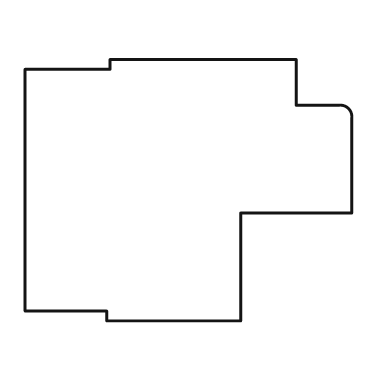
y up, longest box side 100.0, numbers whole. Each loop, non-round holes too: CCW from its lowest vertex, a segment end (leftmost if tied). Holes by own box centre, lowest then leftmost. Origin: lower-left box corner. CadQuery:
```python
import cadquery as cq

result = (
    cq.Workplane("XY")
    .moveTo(25.0, 0.0)
    .lineTo(66.0, 0.0)
    .lineTo(66.0, 33.0)
    .lineTo(100.0, 33.0)
    .lineTo(100.0, 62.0)
    .threePointArc((99.0, 65.0), (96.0, 66.0))
    .lineTo(83.0, 66.0)
    .lineTo(83.0, 80.0)
    .lineTo(26.0, 80.0)
    .lineTo(26.0, 77.0)
    .lineTo(0.0, 77.0)
    .lineTo(0.0, 3.0)
    .lineTo(25.0, 3.0)
    .close()
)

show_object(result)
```